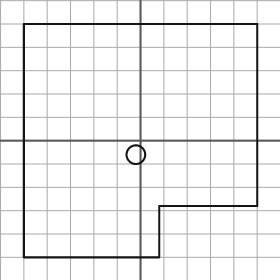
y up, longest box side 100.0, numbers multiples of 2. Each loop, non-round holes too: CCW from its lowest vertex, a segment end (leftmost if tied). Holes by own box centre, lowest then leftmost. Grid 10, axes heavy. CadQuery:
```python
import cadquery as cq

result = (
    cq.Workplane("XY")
    .moveTo(-50.0, -50.0)
    .lineTo(8.0, -50.0)
    .lineTo(8.0, -28.0)
    .lineTo(50.0, -28.0)
    .lineTo(50.0, 50.0)
    .lineTo(-50.0, 50.0)
    .close()
    .moveTo(-2.0, -6.0)
    .circle(4.0)
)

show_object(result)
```